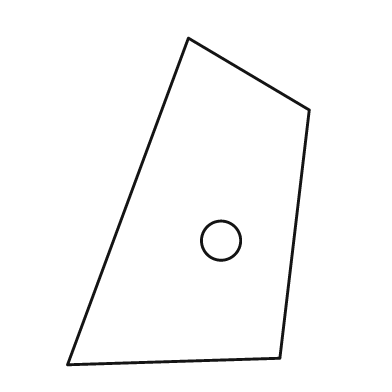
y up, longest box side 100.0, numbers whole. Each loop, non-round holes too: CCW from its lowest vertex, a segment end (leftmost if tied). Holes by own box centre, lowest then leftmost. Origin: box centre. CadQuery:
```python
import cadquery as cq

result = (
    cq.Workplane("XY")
    .moveTo(-37.0, -50.0)
    .lineTo(28.0, -48.0)
    .lineTo(37.0, 28.0)
    .lineTo(0.0, 50.0)
    .close()
    .moveTo(10.0, -12.0)
    .circle(6.0)
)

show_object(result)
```